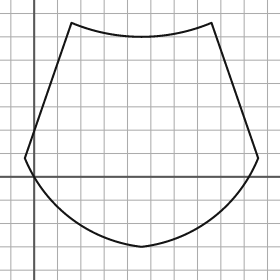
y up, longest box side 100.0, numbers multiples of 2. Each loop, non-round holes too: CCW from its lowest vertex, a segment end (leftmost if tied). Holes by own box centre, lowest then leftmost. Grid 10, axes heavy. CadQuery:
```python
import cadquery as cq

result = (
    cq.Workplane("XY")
    .moveTo(46.0, -30.0)
    .threePointArc((76.0, -18.0), (96.0, 8.0))
    .lineTo(76.0, 66.0)
    .threePointArc((46.0, 60.0), (16.0, 66.0))
    .lineTo(-4.0, 8.0)
    .threePointArc((16.0, -18.0), (46.0, -30.0))
    .close()
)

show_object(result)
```